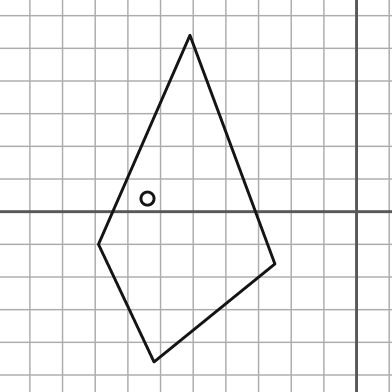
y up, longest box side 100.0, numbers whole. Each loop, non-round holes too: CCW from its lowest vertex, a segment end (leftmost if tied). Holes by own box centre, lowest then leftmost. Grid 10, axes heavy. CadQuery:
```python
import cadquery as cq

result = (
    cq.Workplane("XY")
    .moveTo(-62.0, -46.0)
    .lineTo(-25.0, -16.0)
    .lineTo(-51.0, 54.0)
    .lineTo(-79.0, -10.0)
    .close()
    .moveTo(-64.0, 4.0)
    .circle(2.0)
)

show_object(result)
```